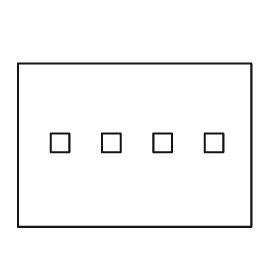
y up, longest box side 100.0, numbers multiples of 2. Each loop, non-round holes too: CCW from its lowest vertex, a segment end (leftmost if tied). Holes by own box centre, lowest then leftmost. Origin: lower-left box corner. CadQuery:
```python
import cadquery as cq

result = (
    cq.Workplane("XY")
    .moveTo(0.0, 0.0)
    .lineTo(100.0, 0.0)
    .lineTo(100.0, 70.0)
    .lineTo(0.0, 70.0)
    .close()
    .moveTo(14.0, 32.0)
    .lineTo(22.0, 32.0)
    .lineTo(22.0, 40.0)
    .lineTo(14.0, 40.0)
    .close()
    .moveTo(36.0, 32.0)
    .lineTo(44.0, 32.0)
    .lineTo(44.0, 40.0)
    .lineTo(36.0, 40.0)
    .close()
    .moveTo(58.0, 32.0)
    .lineTo(66.0, 32.0)
    .lineTo(66.0, 40.0)
    .lineTo(58.0, 40.0)
    .close()
    .moveTo(80.0, 32.0)
    .lineTo(88.0, 32.0)
    .lineTo(88.0, 40.0)
    .lineTo(80.0, 40.0)
    .close()
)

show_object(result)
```